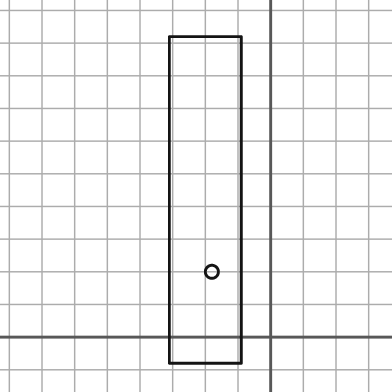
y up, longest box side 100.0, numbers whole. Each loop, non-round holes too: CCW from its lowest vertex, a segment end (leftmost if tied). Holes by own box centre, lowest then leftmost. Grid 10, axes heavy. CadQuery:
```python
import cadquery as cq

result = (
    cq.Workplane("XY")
    .moveTo(-31.0, -8.0)
    .lineTo(-9.0, -8.0)
    .lineTo(-9.0, 92.0)
    .lineTo(-31.0, 92.0)
    .close()
    .moveTo(-18.0, 20.0)
    .circle(2.0)
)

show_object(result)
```